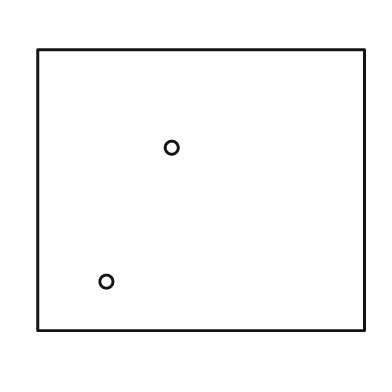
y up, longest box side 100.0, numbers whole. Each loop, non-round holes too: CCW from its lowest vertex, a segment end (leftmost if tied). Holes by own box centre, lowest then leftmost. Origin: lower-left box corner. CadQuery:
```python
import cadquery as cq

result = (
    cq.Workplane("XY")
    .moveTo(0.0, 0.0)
    .lineTo(100.0, 0.0)
    .lineTo(100.0, 86.0)
    .lineTo(0.0, 86.0)
    .close()
    .moveTo(21.0, 15.0)
    .circle(2.0)
    .moveTo(41.0, 56.0)
    .circle(2.0)
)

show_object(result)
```